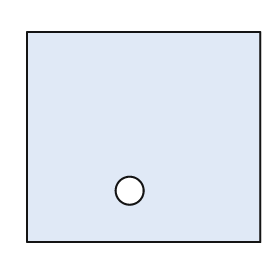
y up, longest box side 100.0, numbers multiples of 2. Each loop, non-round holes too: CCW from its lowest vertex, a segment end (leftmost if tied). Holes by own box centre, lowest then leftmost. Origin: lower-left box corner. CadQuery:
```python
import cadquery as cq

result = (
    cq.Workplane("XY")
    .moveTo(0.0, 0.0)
    .lineTo(100.0, 0.0)
    .lineTo(100.0, 90.0)
    .lineTo(0.0, 90.0)
    .close()
    .moveTo(44.0, 22.0)
    .circle(6.0)
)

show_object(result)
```